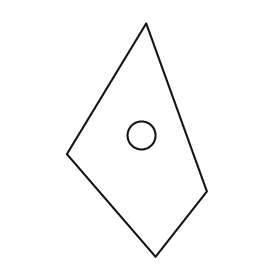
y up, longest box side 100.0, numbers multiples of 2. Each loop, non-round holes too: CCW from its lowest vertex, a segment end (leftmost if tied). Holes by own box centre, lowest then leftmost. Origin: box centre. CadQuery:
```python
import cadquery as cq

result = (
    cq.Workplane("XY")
    .moveTo(8.0, -50.0)
    .lineTo(30.0, -22.0)
    .lineTo(4.0, 50.0)
    .lineTo(-30.0, -6.0)
    .close()
    .moveTo(2.0, 2.0)
    .circle(6.0)
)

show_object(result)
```